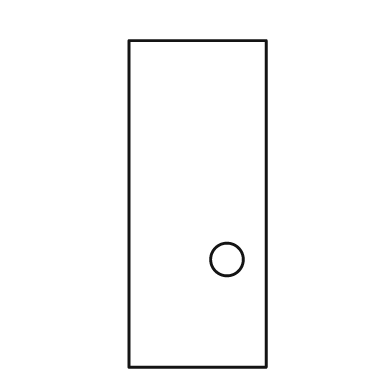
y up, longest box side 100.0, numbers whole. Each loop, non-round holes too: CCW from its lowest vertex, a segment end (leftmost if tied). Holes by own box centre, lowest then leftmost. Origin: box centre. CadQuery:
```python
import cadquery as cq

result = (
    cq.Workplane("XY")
    .moveTo(-21.0, -50.0)
    .lineTo(21.0, -50.0)
    .lineTo(21.0, 50.0)
    .lineTo(-21.0, 50.0)
    .close()
    .moveTo(9.0, -17.0)
    .circle(5.0)
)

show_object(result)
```